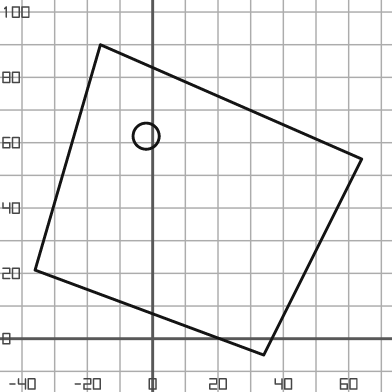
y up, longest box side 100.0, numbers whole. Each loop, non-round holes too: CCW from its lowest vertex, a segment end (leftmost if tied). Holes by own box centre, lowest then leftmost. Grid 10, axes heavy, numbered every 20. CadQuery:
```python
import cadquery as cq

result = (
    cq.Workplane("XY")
    .moveTo(34.0, -5.0)
    .lineTo(64.0, 55.0)
    .lineTo(-16.0, 90.0)
    .lineTo(-36.0, 21.0)
    .close()
    .moveTo(-2.0, 62.0)
    .circle(4.0)
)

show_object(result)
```